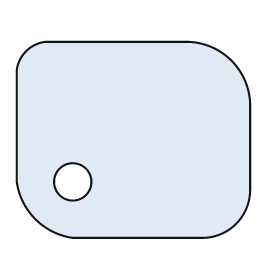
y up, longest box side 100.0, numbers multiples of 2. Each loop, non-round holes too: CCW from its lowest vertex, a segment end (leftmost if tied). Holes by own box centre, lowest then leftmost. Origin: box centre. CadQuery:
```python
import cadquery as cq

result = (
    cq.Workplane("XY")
    .moveTo(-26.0, -42.0)
    .lineTo(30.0, -42.0)
    .threePointArc((44.0, -36.0), (50.0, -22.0))
    .lineTo(50.0, 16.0)
    .threePointArc((42.0, 34.0), (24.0, 42.0))
    .lineTo(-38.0, 42.0)
    .threePointArc((-46.0, 38.0), (-50.0, 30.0))
    .lineTo(-50.0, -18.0)
    .threePointArc((-42.0, -34.0), (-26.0, -42.0))
    .close()
    .moveTo(-26.0, -18.0)
    .circle(8.0)
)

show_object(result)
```